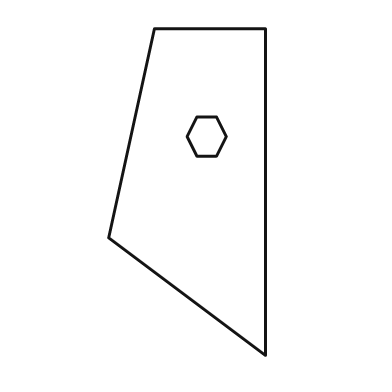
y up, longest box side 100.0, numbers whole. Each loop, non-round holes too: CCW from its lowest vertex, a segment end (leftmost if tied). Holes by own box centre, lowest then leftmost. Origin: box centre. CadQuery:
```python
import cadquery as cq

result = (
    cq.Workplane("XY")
    .moveTo(24.0, -50.0)
    .lineTo(24.0, 50.0)
    .lineTo(-10.0, 50.0)
    .lineTo(-24.0, -14.0)
    .close()
    .moveTo(3.0, 11.0)
    .lineTo(9.0, 11.0)
    .lineTo(12.0, 17.0)
    .lineTo(9.0, 23.0)
    .lineTo(3.0, 23.0)
    .lineTo(0.0, 17.0)
    .close()
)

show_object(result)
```